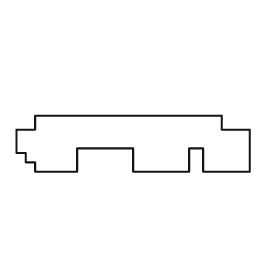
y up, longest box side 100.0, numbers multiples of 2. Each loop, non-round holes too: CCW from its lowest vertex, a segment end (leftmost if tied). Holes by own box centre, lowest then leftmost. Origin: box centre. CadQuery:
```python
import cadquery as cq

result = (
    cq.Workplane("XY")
    .moveTo(-42.0, -12.0)
    .lineTo(-24.0, -12.0)
    .lineTo(-24.0, -2.0)
    .lineTo(0.0, -2.0)
    .lineTo(0.0, -12.0)
    .lineTo(24.0, -12.0)
    .lineTo(24.0, -2.0)
    .lineTo(30.0, -2.0)
    .lineTo(30.0, -12.0)
    .lineTo(50.0, -12.0)
    .lineTo(50.0, 6.0)
    .lineTo(38.0, 6.0)
    .lineTo(38.0, 12.0)
    .lineTo(-42.0, 12.0)
    .lineTo(-42.0, 6.0)
    .lineTo(-50.0, 6.0)
    .lineTo(-50.0, -4.0)
    .lineTo(-46.0, -4.0)
    .lineTo(-46.0, -8.0)
    .lineTo(-42.0, -8.0)
    .close()
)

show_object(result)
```